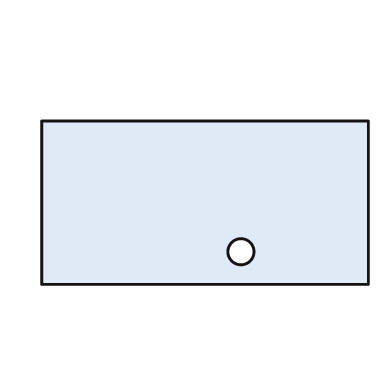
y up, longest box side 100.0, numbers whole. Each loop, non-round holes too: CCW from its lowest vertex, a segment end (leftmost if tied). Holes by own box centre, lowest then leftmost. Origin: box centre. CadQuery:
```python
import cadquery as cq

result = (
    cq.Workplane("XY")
    .moveTo(-50.0, -25.0)
    .lineTo(50.0, -25.0)
    .lineTo(50.0, 25.0)
    .lineTo(-50.0, 25.0)
    .close()
    .moveTo(11.0, -15.0)
    .circle(4.0)
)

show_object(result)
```